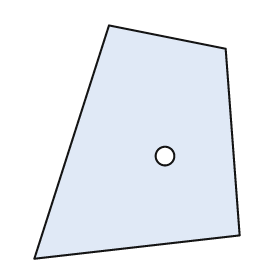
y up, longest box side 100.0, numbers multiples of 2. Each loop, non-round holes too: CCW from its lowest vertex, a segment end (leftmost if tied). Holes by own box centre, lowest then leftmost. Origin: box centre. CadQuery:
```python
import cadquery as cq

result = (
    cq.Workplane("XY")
    .moveTo(-44.0, -50.0)
    .lineTo(44.0, -40.0)
    .lineTo(38.0, 40.0)
    .lineTo(-12.0, 50.0)
    .close()
    .moveTo(12.0, -6.0)
    .circle(4.0)
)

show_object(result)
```